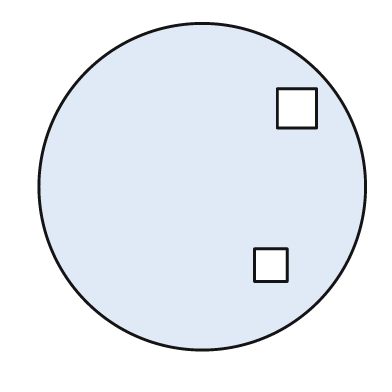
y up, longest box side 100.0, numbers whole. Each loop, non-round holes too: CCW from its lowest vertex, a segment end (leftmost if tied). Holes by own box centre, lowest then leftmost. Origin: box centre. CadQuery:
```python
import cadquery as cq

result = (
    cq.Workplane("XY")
    .moveTo(0.0, 0.0)
    .circle(50.0)
    .moveTo(16.0, -29.0)
    .lineTo(26.0, -29.0)
    .lineTo(26.0, -19.0)
    .lineTo(16.0, -19.0)
    .close()
    .moveTo(23.0, 18.0)
    .lineTo(35.0, 18.0)
    .lineTo(35.0, 30.0)
    .lineTo(23.0, 30.0)
    .close()
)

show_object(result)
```